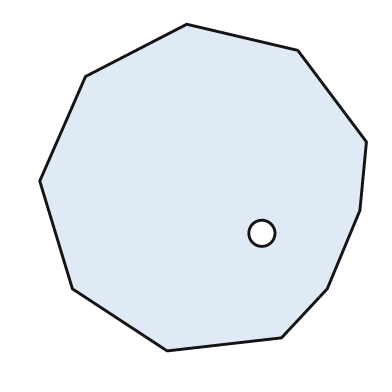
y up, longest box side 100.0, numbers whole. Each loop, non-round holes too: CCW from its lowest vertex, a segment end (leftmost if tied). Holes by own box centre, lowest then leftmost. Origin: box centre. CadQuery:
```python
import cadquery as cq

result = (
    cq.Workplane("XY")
    .moveTo(-11.0, -50.0)
    .lineTo(24.0, -46.0)
    .lineTo(38.0, -31.0)
    .lineTo(48.0, -7.0)
    .lineTo(50.0, 14.0)
    .lineTo(29.0, 42.0)
    .lineTo(-5.0, 50.0)
    .lineTo(-36.0, 34.0)
    .lineTo(-50.0, 2.0)
    .lineTo(-40.0, -31.0)
    .close()
    .moveTo(18.0, -14.0)
    .circle(4.0)
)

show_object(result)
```